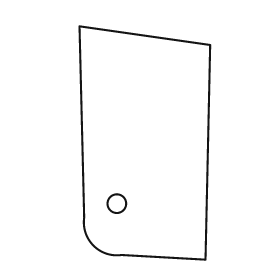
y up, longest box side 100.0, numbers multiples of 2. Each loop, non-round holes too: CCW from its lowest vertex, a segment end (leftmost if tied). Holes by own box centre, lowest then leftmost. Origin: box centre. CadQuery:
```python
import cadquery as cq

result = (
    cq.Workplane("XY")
    .moveTo(26.0, -50.0)
    .lineTo(28.0, 42.0)
    .lineTo(-28.0, 50.0)
    .lineTo(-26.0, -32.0)
    .threePointArc((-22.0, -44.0), (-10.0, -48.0))
    .close()
    .moveTo(-12.0, -26.0)
    .circle(4.0)
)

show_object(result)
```